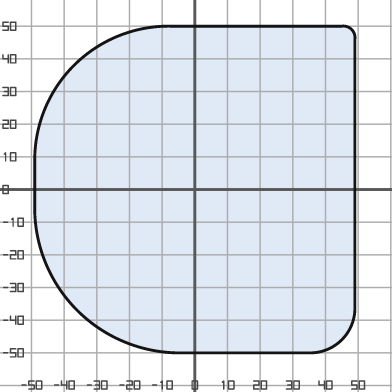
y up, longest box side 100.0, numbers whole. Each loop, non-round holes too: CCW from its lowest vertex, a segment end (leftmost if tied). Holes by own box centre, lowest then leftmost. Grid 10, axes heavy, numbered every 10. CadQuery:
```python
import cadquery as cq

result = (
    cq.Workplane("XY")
    .moveTo(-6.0, -50.0)
    .lineTo(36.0, -50.0)
    .threePointArc((45.0, -46.0), (49.0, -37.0))
    .lineTo(49.0, 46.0)
    .threePointArc((48.0, 49.0), (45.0, 50.0))
    .lineTo(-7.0, 50.0)
    .threePointArc((-37.0, 38.0), (-49.0, 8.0))
    .lineTo(-49.0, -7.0)
    .threePointArc((-36.0, -37.0), (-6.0, -50.0))
    .close()
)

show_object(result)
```